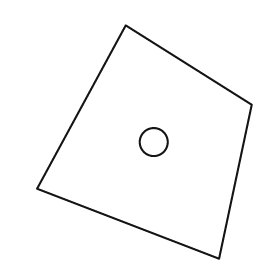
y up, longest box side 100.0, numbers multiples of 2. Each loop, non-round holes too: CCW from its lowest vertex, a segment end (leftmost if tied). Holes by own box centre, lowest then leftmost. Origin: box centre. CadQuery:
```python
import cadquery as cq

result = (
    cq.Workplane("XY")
    .moveTo(32.0, -50.0)
    .lineTo(46.0, 16.0)
    .lineTo(-8.0, 50.0)
    .lineTo(-46.0, -20.0)
    .close()
    .moveTo(4.0, 0.0)
    .circle(6.0)
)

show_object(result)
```